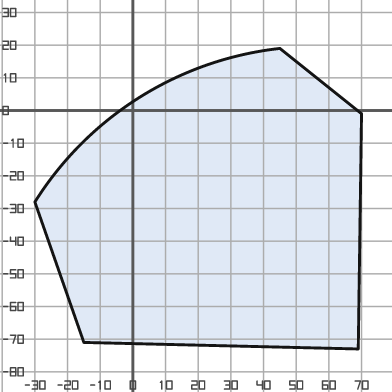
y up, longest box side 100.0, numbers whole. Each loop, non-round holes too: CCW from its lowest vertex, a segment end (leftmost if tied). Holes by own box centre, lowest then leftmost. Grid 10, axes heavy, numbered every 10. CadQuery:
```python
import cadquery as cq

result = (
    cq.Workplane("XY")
    .moveTo(69.0, -73.0)
    .lineTo(70.0, -1.0)
    .lineTo(45.0, 19.0)
    .threePointArc((2.0, 4.0), (-30.0, -28.0))
    .lineTo(-15.0, -71.0)
    .close()
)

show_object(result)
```